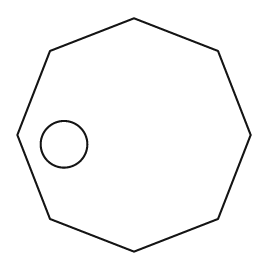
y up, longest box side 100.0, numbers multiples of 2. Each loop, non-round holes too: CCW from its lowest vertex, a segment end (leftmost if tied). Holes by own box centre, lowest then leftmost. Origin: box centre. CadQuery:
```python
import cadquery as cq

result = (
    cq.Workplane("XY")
    .moveTo(0.0, -50.0)
    .lineTo(36.0, -36.0)
    .lineTo(50.0, 0.0)
    .lineTo(36.0, 36.0)
    .lineTo(0.0, 50.0)
    .lineTo(-36.0, 36.0)
    .lineTo(-50.0, 0.0)
    .lineTo(-36.0, -36.0)
    .close()
    .moveTo(-30.0, -4.0)
    .circle(10.0)
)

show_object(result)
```